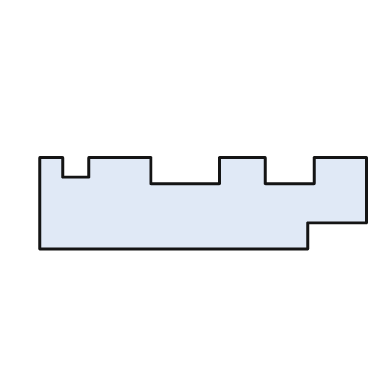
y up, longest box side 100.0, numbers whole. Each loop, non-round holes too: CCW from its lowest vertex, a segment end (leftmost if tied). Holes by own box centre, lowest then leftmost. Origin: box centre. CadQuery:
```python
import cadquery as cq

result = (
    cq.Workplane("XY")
    .moveTo(-50.0, -14.0)
    .lineTo(32.0, -14.0)
    .lineTo(32.0, -6.0)
    .lineTo(50.0, -6.0)
    .lineTo(50.0, 14.0)
    .lineTo(34.0, 14.0)
    .lineTo(34.0, 6.0)
    .lineTo(19.0, 6.0)
    .lineTo(19.0, 14.0)
    .lineTo(5.0, 14.0)
    .lineTo(5.0, 6.0)
    .lineTo(-16.0, 6.0)
    .lineTo(-16.0, 14.0)
    .lineTo(-35.0, 14.0)
    .lineTo(-35.0, 8.0)
    .lineTo(-43.0, 8.0)
    .lineTo(-43.0, 14.0)
    .lineTo(-50.0, 14.0)
    .close()
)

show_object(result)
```